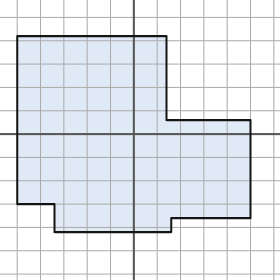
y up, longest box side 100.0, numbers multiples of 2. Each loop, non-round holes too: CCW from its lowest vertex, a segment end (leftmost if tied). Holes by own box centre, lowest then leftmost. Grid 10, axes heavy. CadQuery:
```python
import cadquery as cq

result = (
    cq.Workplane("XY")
    .moveTo(-34.0, -42.0)
    .lineTo(16.0, -42.0)
    .lineTo(16.0, -36.0)
    .lineTo(50.0, -36.0)
    .lineTo(50.0, 6.0)
    .lineTo(14.0, 6.0)
    .lineTo(14.0, 42.0)
    .lineTo(-50.0, 42.0)
    .lineTo(-50.0, -30.0)
    .lineTo(-34.0, -30.0)
    .close()
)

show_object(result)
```